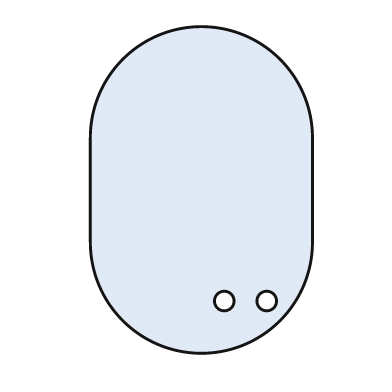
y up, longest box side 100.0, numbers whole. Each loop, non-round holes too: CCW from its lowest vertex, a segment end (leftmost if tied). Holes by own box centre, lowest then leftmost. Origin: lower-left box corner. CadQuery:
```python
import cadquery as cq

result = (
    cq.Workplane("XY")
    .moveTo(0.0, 34.0)
    .threePointArc((34.0, 0.0), (68.0, 34.0))
    .lineTo(68.0, 66.0)
    .threePointArc((34.0, 100.0), (0.0, 66.0))
    .close()
    .moveTo(41.0, 16.0)
    .circle(3.0)
    .moveTo(54.0, 16.0)
    .circle(3.0)
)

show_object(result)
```